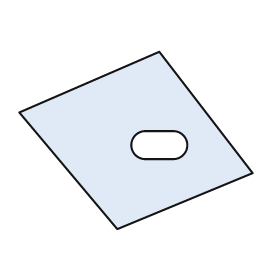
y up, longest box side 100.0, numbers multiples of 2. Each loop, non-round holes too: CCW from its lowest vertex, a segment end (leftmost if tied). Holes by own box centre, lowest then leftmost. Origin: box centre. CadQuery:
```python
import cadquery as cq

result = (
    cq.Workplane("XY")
    .moveTo(-8.0, -38.0)
    .lineTo(50.0, -14.0)
    .lineTo(10.0, 38.0)
    .lineTo(-50.0, 12.0)
    .close()
    .moveTo(4.0, -8.0)
    .lineTo(16.0, -8.0)
    .threePointArc((22.0, -2.0), (16.0, 4.0))
    .lineTo(4.0, 4.0)
    .threePointArc((-2.0, -2.0), (4.0, -8.0))
    .close()
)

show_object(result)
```